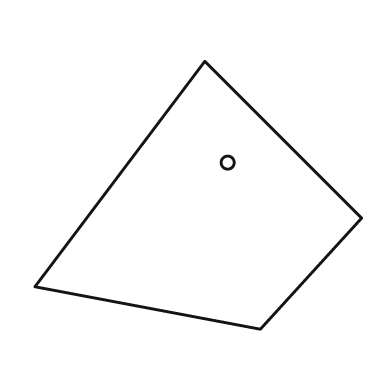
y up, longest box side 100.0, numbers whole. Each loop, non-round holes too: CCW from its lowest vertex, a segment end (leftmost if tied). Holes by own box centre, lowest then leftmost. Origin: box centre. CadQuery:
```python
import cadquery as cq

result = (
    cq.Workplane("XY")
    .moveTo(19.0, -41.0)
    .lineTo(50.0, -7.0)
    .lineTo(2.0, 41.0)
    .lineTo(-50.0, -28.0)
    .close()
    .moveTo(9.0, 10.0)
    .circle(2.0)
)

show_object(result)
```